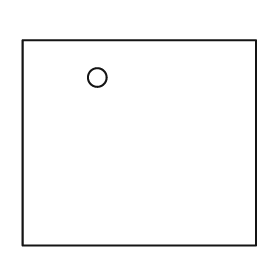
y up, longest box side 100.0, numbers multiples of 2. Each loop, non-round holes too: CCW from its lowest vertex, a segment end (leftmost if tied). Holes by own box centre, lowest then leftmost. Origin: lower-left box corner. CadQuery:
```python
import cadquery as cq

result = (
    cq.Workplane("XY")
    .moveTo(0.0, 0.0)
    .lineTo(100.0, 0.0)
    .lineTo(100.0, 88.0)
    .lineTo(0.0, 88.0)
    .close()
    .moveTo(32.0, 72.0)
    .circle(4.0)
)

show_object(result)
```